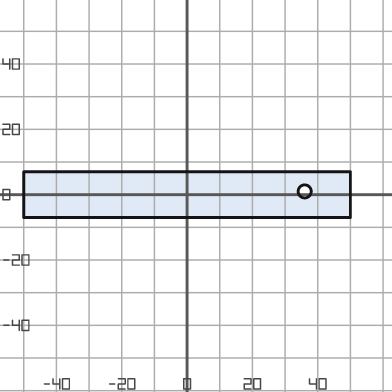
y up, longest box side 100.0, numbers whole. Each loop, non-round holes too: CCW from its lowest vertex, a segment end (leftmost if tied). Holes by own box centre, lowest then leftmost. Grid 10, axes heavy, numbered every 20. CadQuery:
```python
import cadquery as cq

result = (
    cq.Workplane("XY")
    .moveTo(-50.0, -7.0)
    .lineTo(50.0, -7.0)
    .lineTo(50.0, 7.0)
    .lineTo(-50.0, 7.0)
    .close()
    .moveTo(36.0, 1.0)
    .circle(2.0)
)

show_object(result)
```